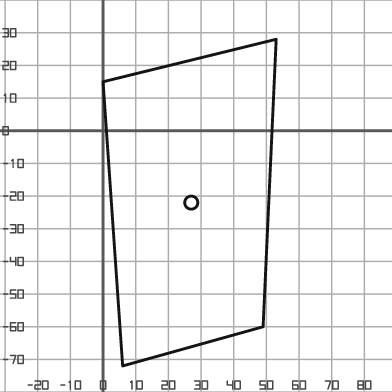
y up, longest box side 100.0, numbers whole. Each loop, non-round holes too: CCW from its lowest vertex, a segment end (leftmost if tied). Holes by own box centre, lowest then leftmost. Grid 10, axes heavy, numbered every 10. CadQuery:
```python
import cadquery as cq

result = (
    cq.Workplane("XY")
    .moveTo(6.0, -72.0)
    .lineTo(49.0, -60.0)
    .lineTo(53.0, 28.0)
    .lineTo(0.0, 15.0)
    .close()
    .moveTo(27.0, -22.0)
    .circle(2.0)
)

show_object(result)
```